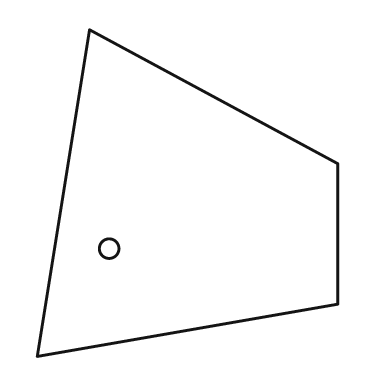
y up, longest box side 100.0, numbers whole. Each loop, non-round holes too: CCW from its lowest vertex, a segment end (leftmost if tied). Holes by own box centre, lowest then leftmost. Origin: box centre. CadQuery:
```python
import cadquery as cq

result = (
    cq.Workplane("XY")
    .moveTo(-46.0, -50.0)
    .lineTo(46.0, -34.0)
    .lineTo(46.0, 9.0)
    .lineTo(-30.0, 50.0)
    .close()
    .moveTo(-24.0, -17.0)
    .circle(3.0)
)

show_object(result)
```